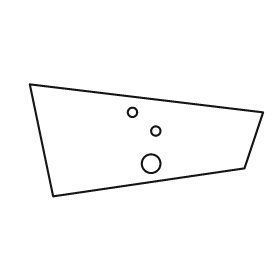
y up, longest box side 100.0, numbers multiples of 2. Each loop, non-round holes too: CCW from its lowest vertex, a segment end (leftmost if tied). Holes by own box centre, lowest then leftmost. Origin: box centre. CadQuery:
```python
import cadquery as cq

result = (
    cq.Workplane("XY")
    .moveTo(-40.0, -24.0)
    .lineTo(42.0, -12.0)
    .lineTo(50.0, 12.0)
    .lineTo(-50.0, 24.0)
    .close()
    .moveTo(2.0, -10.0)
    .circle(4.0)
    .moveTo(4.0, 4.0)
    .circle(2.0)
    .moveTo(-6.0, 12.0)
    .circle(2.0)
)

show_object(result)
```